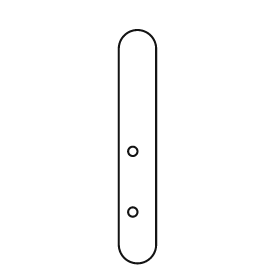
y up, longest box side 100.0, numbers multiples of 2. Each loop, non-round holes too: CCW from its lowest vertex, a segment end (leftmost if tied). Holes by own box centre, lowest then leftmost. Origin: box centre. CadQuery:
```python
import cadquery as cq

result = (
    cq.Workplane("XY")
    .moveTo(-8.0, -42.0)
    .threePointArc((0.0, -50.0), (8.0, -42.0))
    .lineTo(8.0, 42.0)
    .threePointArc((0.0, 50.0), (-8.0, 42.0))
    .close()
    .moveTo(-2.0, -28.0)
    .circle(2.0)
    .moveTo(-2.0, -2.0)
    .circle(2.0)
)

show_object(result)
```